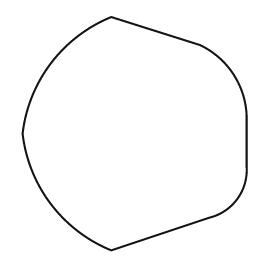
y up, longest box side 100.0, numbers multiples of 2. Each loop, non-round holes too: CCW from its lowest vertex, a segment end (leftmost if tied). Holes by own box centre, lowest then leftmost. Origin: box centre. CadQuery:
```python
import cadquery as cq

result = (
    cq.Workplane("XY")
    .moveTo(-10.0, -50.0)
    .lineTo(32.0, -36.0)
    .threePointArc((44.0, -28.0), (48.0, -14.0))
    .lineTo(48.0, 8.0)
    .threePointArc((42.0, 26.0), (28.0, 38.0))
    .lineTo(-10.0, 50.0)
    .threePointArc((-36.0, 30.0), (-48.0, 0.0))
    .threePointArc((-36.0, -30.0), (-10.0, -50.0))
    .close()
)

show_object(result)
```